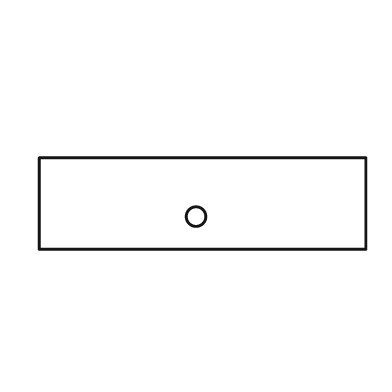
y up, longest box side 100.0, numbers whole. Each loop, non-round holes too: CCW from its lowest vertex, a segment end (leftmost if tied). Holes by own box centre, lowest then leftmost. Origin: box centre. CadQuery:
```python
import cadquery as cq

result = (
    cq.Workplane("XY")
    .moveTo(-50.0, -14.0)
    .lineTo(50.0, -14.0)
    .lineTo(50.0, 14.0)
    .lineTo(-50.0, 14.0)
    .close()
    .moveTo(-2.0, -4.0)
    .circle(3.0)
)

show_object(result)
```